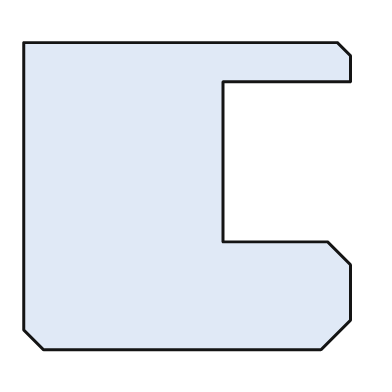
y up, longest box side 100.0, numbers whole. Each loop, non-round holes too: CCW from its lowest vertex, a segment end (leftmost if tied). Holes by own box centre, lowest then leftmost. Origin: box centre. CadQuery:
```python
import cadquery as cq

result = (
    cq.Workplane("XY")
    .moveTo(-44.0, -47.0)
    .lineTo(41.0, -47.0)
    .lineTo(50.0, -38.0)
    .lineTo(50.0, -21.0)
    .lineTo(43.0, -14.0)
    .lineTo(11.0, -14.0)
    .lineTo(11.0, 35.0)
    .lineTo(50.0, 35.0)
    .lineTo(50.0, 43.0)
    .lineTo(46.0, 47.0)
    .lineTo(-50.0, 47.0)
    .lineTo(-50.0, -41.0)
    .close()
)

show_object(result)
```